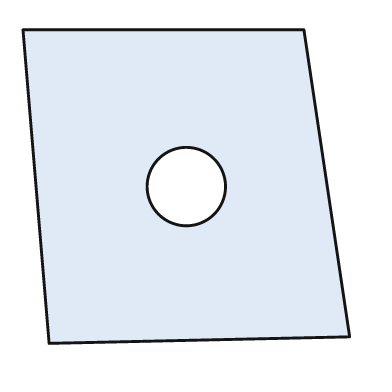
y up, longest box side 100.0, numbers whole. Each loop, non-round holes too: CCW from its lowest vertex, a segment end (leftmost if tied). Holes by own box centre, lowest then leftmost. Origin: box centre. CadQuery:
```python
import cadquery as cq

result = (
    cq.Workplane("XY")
    .moveTo(-42.0, -48.0)
    .lineTo(50.0, -46.0)
    .lineTo(36.0, 48.0)
    .lineTo(-50.0, 48.0)
    .close()
    .moveTo(0.0, 0.0)
    .circle(12.0)
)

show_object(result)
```